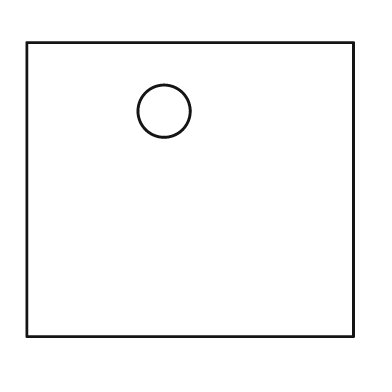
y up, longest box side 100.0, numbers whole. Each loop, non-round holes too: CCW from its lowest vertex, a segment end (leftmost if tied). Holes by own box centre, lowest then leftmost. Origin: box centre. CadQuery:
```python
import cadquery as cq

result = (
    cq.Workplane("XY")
    .moveTo(-50.0, -45.0)
    .lineTo(50.0, -45.0)
    .lineTo(50.0, 45.0)
    .lineTo(-50.0, 45.0)
    .close()
    .moveTo(-8.0, 24.0)
    .circle(8.0)
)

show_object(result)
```